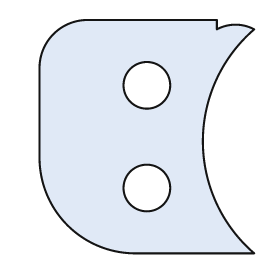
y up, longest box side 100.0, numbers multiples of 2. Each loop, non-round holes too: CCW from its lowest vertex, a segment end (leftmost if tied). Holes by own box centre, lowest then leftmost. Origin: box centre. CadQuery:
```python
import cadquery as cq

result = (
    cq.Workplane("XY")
    .moveTo(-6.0, -50.0)
    .lineTo(46.0, -50.0)
    .threePointArc((24.0, -2.0), (46.0, 46.0))
    .threePointArc((38.0, 48.0), (30.0, 46.0))
    .lineTo(30.0, 50.0)
    .lineTo(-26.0, 50.0)
    .threePointArc((-40.0, 44.0), (-46.0, 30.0))
    .lineTo(-46.0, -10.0)
    .threePointArc((-34.0, -38.0), (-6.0, -50.0))
    .close()
    .moveTo(0.0, -22.0)
    .circle(10.0)
    .moveTo(0.0, 22.0)
    .circle(10.0)
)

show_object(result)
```